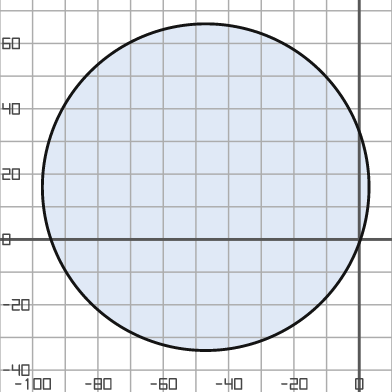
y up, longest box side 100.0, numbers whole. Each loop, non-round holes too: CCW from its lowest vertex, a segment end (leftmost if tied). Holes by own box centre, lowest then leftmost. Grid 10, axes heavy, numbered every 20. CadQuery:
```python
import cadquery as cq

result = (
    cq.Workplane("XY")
    .moveTo(-47.0, 16.0)
    .circle(50.0)
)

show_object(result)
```